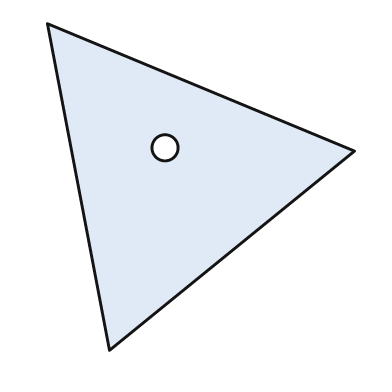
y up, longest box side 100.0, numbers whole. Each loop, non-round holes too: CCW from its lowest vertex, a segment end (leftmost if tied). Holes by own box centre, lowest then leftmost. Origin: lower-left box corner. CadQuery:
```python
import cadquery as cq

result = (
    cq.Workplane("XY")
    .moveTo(19.0, 0.0)
    .lineTo(94.0, 61.0)
    .lineTo(0.0, 100.0)
    .close()
    .moveTo(36.0, 62.0)
    .circle(4.0)
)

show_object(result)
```